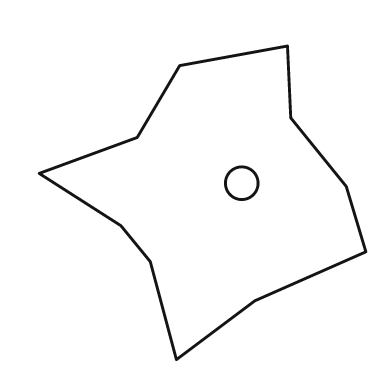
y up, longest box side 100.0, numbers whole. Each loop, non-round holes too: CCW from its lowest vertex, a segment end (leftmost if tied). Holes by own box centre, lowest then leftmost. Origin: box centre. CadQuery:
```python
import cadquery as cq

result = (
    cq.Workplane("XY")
    .moveTo(-8.0, -48.0)
    .lineTo(16.0, -30.0)
    .lineTo(50.0, -15.0)
    .lineTo(44.0, 5.0)
    .lineTo(27.0, 26.0)
    .lineTo(26.0, 48.0)
    .lineTo(-7.0, 42.0)
    .lineTo(-20.0, 20.0)
    .lineTo(-50.0, 9.0)
    .lineTo(-25.0, -7.0)
    .lineTo(-16.0, -18.0)
    .close()
    .moveTo(12.0, 6.0)
    .circle(5.0)
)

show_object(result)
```